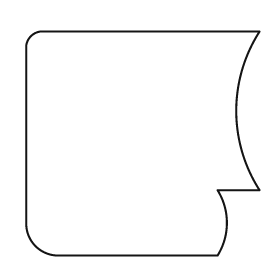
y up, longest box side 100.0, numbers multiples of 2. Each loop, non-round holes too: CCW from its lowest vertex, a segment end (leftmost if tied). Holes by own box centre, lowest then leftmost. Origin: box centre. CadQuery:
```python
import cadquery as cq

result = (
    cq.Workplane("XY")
    .moveTo(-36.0, -48.0)
    .lineTo(32.0, -48.0)
    .threePointArc((36.0, -34.0), (32.0, -20.0))
    .lineTo(50.0, -20.0)
    .threePointArc((40.0, 14.0), (50.0, 48.0))
    .lineTo(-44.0, 48.0)
    .threePointArc((-48.0, 46.0), (-50.0, 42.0))
    .lineTo(-50.0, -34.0)
    .threePointArc((-46.0, -44.0), (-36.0, -48.0))
    .close()
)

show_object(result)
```